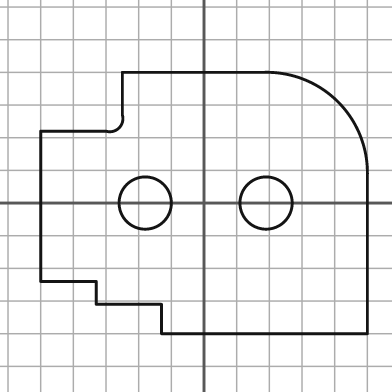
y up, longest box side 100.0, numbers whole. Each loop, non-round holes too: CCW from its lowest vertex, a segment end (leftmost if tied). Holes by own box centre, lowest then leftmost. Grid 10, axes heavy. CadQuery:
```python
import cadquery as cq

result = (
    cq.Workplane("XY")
    .moveTo(-13.0, -40.0)
    .lineTo(50.0, -40.0)
    .lineTo(50.0, 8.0)
    .threePointArc((41.0, 31.0), (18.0, 40.0))
    .lineTo(-25.0, 40.0)
    .lineTo(-25.0, 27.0)
    .threePointArc((-26.0, 23.0), (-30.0, 22.0))
    .lineTo(-50.0, 22.0)
    .lineTo(-50.0, -24.0)
    .lineTo(-33.0, -24.0)
    .lineTo(-33.0, -31.0)
    .lineTo(-13.0, -31.0)
    .close()
    .moveTo(-18.0, 0.0)
    .circle(8.0)
    .moveTo(19.0, 0.0)
    .circle(8.0)
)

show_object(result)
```